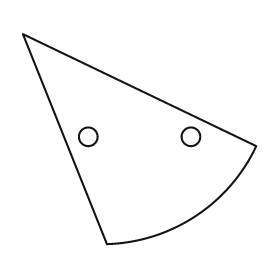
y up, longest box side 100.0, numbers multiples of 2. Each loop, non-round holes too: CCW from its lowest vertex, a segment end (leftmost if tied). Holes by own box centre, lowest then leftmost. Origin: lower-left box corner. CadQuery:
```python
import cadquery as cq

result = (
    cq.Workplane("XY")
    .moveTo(36.0, 0.0)
    .threePointArc((74.0, 12.0), (100.0, 42.0))
    .lineTo(0.0, 90.0)
    .close()
    .moveTo(28.0, 46.0)
    .circle(4.0)
    .moveTo(72.0, 46.0)
    .circle(4.0)
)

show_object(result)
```